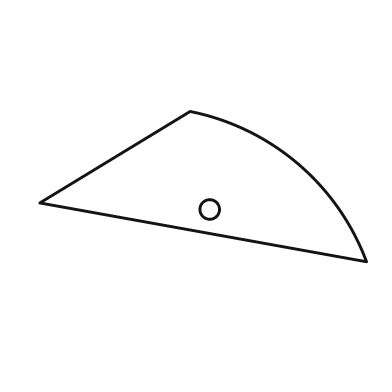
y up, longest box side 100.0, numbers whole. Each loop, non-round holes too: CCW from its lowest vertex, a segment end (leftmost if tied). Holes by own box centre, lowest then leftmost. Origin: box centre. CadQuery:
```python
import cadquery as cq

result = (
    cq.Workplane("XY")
    .moveTo(50.0, -23.0)
    .threePointArc((29.0, 7.0), (-4.0, 23.0))
    .lineTo(-50.0, -5.0)
    .close()
    .moveTo(2.0, -7.0)
    .circle(3.0)
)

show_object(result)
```